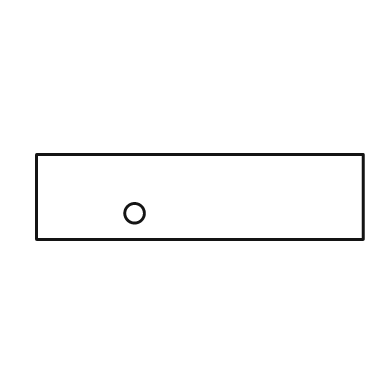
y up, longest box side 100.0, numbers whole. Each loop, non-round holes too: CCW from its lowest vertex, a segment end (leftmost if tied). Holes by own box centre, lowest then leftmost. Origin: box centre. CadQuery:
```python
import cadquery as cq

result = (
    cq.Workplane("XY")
    .moveTo(-50.0, -13.0)
    .lineTo(50.0, -13.0)
    .lineTo(50.0, 13.0)
    .lineTo(-50.0, 13.0)
    .close()
    .moveTo(-20.0, -5.0)
    .circle(3.0)
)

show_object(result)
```